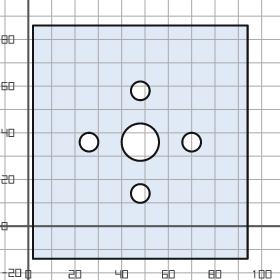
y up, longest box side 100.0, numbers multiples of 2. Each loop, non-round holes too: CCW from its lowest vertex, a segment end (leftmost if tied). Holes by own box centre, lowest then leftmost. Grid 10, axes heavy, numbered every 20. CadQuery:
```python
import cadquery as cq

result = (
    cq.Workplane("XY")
    .moveTo(2.0, -14.0)
    .lineTo(94.0, -14.0)
    .lineTo(94.0, 86.0)
    .lineTo(2.0, 86.0)
    .close()
    .moveTo(48.0, 14.0)
    .circle(4.0)
    .moveTo(26.0, 36.0)
    .circle(4.0)
    .moveTo(48.0, 36.0)
    .circle(8.0)
    .moveTo(70.0, 36.0)
    .circle(4.0)
    .moveTo(48.0, 58.0)
    .circle(4.0)
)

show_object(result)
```